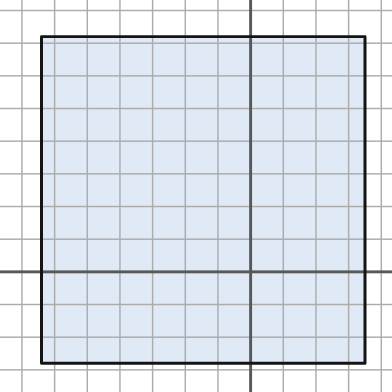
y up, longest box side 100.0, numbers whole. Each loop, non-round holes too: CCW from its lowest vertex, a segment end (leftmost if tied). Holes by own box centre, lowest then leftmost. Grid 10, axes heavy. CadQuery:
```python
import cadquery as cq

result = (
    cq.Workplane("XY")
    .moveTo(-64.0, -28.0)
    .lineTo(35.0, -28.0)
    .lineTo(35.0, 72.0)
    .lineTo(-64.0, 72.0)
    .close()
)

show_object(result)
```